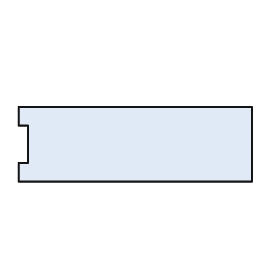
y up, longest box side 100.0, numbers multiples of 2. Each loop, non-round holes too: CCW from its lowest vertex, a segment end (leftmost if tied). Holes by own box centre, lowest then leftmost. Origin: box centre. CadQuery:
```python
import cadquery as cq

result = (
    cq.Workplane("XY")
    .moveTo(-50.0, -16.0)
    .lineTo(50.0, -16.0)
    .lineTo(50.0, 16.0)
    .lineTo(-50.0, 16.0)
    .lineTo(-50.0, 8.0)
    .lineTo(-46.0, 8.0)
    .lineTo(-46.0, -8.0)
    .lineTo(-50.0, -8.0)
    .close()
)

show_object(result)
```